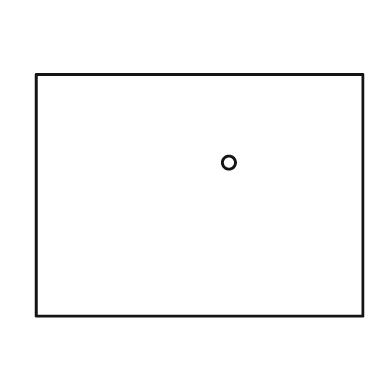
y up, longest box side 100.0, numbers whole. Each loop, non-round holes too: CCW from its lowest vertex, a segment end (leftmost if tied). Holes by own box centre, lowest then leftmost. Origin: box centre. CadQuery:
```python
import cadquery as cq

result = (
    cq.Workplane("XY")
    .moveTo(-50.0, -37.0)
    .lineTo(50.0, -37.0)
    .lineTo(50.0, 37.0)
    .lineTo(-50.0, 37.0)
    .close()
    .moveTo(9.0, 10.0)
    .circle(2.0)
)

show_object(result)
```